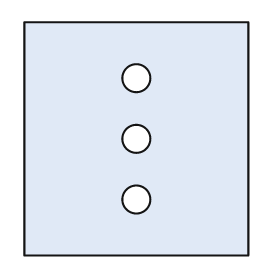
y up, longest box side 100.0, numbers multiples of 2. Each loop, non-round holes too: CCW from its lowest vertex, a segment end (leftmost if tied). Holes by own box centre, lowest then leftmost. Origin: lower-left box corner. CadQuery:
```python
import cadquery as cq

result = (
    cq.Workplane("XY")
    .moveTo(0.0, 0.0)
    .lineTo(96.0, 0.0)
    .lineTo(96.0, 100.0)
    .lineTo(0.0, 100.0)
    .close()
    .moveTo(48.0, 24.0)
    .circle(6.0)
    .moveTo(48.0, 50.0)
    .circle(6.0)
    .moveTo(48.0, 76.0)
    .circle(6.0)
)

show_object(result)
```